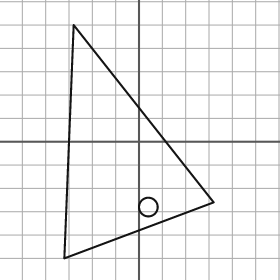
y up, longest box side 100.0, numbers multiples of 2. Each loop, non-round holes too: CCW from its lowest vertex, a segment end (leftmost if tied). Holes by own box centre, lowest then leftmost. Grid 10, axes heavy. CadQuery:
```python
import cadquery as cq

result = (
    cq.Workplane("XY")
    .moveTo(-32.0, -50.0)
    .lineTo(32.0, -26.0)
    .lineTo(-28.0, 50.0)
    .close()
    .moveTo(4.0, -28.0)
    .circle(4.0)
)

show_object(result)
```